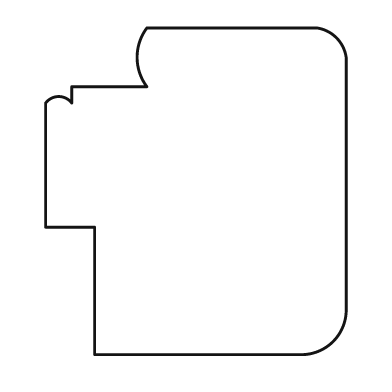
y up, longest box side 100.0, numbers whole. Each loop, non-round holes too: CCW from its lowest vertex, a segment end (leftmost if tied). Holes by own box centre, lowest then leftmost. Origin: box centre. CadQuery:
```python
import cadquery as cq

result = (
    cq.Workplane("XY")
    .moveTo(-31.0, -50.0)
    .lineTo(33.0, -50.0)
    .threePointArc((42.0, -46.0), (46.0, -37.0))
    .lineTo(46.0, 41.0)
    .threePointArc((43.0, 47.0), (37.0, 50.0))
    .lineTo(-15.0, 50.0)
    .threePointArc((-18.0, 41.0), (-15.0, 32.0))
    .lineTo(-38.0, 32.0)
    .lineTo(-38.0, 27.0)
    .threePointArc((-42.0, 29.0), (-46.0, 27.0))
    .lineTo(-46.0, -11.0)
    .lineTo(-31.0, -11.0)
    .close()
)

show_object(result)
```